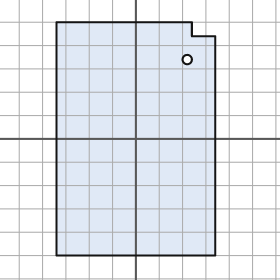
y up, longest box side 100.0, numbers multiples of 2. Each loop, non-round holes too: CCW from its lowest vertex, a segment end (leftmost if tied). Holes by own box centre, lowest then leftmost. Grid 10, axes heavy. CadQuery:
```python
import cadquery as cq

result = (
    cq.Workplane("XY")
    .moveTo(-34.0, -50.0)
    .lineTo(34.0, -50.0)
    .lineTo(34.0, 44.0)
    .lineTo(24.0, 44.0)
    .lineTo(24.0, 50.0)
    .lineTo(-34.0, 50.0)
    .close()
    .moveTo(22.0, 34.0)
    .circle(2.0)
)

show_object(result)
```